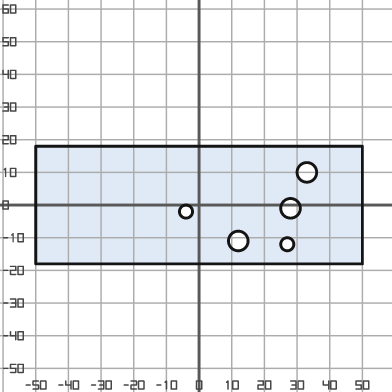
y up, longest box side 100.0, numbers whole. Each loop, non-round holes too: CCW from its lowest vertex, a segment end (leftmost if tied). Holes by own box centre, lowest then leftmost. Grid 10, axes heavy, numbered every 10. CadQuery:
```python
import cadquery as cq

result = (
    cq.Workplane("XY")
    .moveTo(-50.0, -18.0)
    .lineTo(50.0, -18.0)
    .lineTo(50.0, 18.0)
    .lineTo(-50.0, 18.0)
    .close()
    .moveTo(27.0, -12.0)
    .circle(2.0)
    .moveTo(12.0, -11.0)
    .circle(3.0)
    .moveTo(-4.0, -2.0)
    .circle(2.0)
    .moveTo(28.0, -1.0)
    .circle(3.0)
    .moveTo(33.0, 10.0)
    .circle(3.0)
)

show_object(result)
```